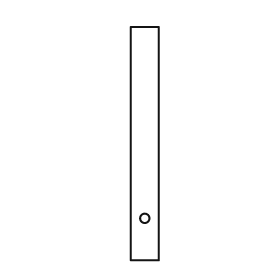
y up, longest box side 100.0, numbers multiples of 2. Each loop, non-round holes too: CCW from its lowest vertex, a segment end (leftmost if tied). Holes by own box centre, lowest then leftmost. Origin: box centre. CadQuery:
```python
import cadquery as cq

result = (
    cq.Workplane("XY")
    .moveTo(-6.0, -50.0)
    .lineTo(6.0, -50.0)
    .lineTo(6.0, 50.0)
    .lineTo(-6.0, 50.0)
    .close()
    .moveTo(0.0, -32.0)
    .circle(2.0)
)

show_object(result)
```